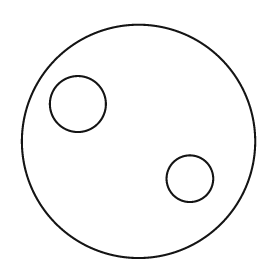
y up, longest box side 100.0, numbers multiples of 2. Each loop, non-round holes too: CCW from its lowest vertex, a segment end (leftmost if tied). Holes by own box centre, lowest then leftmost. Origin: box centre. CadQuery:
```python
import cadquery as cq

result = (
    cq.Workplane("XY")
    .moveTo(0.0, 0.0)
    .circle(50.0)
    .moveTo(22.0, -16.0)
    .circle(10.0)
    .moveTo(-26.0, 16.0)
    .circle(12.0)
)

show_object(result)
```